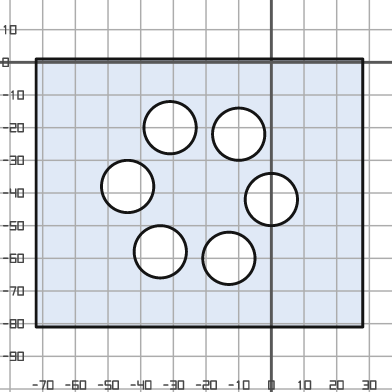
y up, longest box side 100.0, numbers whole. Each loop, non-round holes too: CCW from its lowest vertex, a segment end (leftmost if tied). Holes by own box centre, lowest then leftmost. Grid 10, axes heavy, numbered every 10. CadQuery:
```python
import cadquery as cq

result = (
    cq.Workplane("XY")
    .moveTo(-72.0, -81.0)
    .lineTo(28.0, -81.0)
    .lineTo(28.0, 1.0)
    .lineTo(-72.0, 1.0)
    .close()
    .moveTo(-13.0, -60.0)
    .circle(8.0)
    .moveTo(-34.0, -58.0)
    .circle(8.0)
    .moveTo(0.0, -42.0)
    .circle(8.0)
    .moveTo(-44.0, -38.0)
    .circle(8.0)
    .moveTo(-10.0, -22.0)
    .circle(8.0)
    .moveTo(-31.0, -20.0)
    .circle(8.0)
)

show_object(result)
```